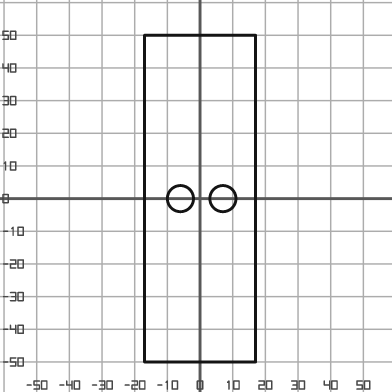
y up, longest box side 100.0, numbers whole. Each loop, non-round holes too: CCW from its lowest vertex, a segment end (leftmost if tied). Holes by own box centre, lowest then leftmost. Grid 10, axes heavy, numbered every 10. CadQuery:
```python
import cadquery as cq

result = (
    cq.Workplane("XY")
    .moveTo(-17.0, -50.0)
    .lineTo(17.0, -50.0)
    .lineTo(17.0, 50.0)
    .lineTo(-17.0, 50.0)
    .close()
    .moveTo(-6.0, 0.0)
    .circle(4.0)
    .moveTo(7.0, 0.0)
    .circle(4.0)
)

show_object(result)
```